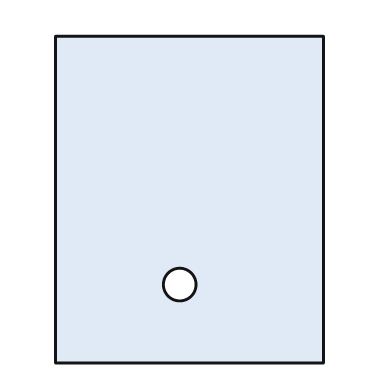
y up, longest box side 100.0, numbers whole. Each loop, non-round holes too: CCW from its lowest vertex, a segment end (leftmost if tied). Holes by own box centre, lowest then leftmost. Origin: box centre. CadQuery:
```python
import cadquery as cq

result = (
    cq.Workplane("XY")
    .moveTo(-41.0, -50.0)
    .lineTo(41.0, -50.0)
    .lineTo(41.0, 50.0)
    .lineTo(-41.0, 50.0)
    .close()
    .moveTo(-3.0, -26.0)
    .circle(5.0)
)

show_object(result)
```